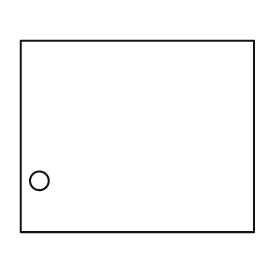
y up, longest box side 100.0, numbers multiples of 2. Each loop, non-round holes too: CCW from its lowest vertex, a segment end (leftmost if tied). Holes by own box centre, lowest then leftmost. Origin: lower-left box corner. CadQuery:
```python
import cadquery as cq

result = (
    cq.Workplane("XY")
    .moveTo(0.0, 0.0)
    .lineTo(100.0, 0.0)
    .lineTo(100.0, 82.0)
    .lineTo(0.0, 82.0)
    .close()
    .moveTo(8.0, 22.0)
    .circle(4.0)
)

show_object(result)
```